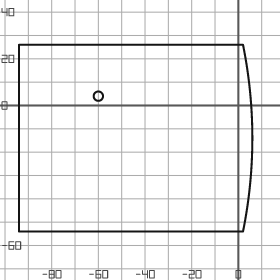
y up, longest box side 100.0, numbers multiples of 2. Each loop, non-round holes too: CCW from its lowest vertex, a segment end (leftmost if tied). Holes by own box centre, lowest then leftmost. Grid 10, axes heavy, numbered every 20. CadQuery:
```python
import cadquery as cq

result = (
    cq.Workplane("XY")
    .moveTo(-94.0, -54.0)
    .lineTo(2.0, -54.0)
    .threePointArc((6.0, -14.0), (2.0, 26.0))
    .lineTo(-94.0, 26.0)
    .close()
    .moveTo(-60.0, 4.0)
    .circle(2.0)
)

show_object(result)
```